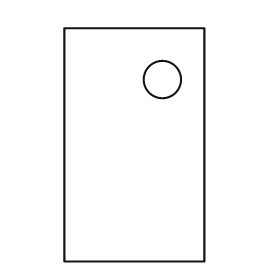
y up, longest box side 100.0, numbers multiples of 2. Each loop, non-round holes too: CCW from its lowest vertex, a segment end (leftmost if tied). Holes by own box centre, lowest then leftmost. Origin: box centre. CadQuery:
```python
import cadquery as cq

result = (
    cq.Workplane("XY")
    .moveTo(-30.0, -50.0)
    .lineTo(30.0, -50.0)
    .lineTo(30.0, 50.0)
    .lineTo(-30.0, 50.0)
    .close()
    .moveTo(12.0, 28.0)
    .circle(8.0)
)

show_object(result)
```